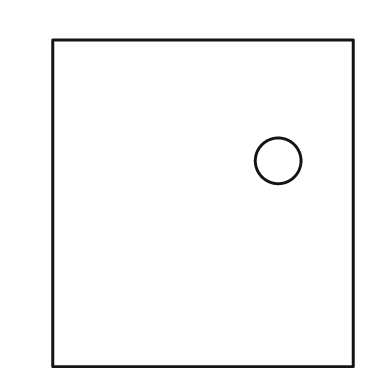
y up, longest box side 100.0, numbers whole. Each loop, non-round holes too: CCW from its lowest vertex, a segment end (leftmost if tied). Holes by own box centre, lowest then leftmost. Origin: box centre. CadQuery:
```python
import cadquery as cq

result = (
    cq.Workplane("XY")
    .moveTo(-46.0, -50.0)
    .lineTo(46.0, -50.0)
    .lineTo(46.0, 50.0)
    .lineTo(-46.0, 50.0)
    .close()
    .moveTo(23.0, 13.0)
    .circle(7.0)
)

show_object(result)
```